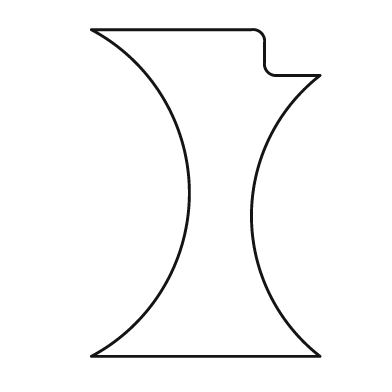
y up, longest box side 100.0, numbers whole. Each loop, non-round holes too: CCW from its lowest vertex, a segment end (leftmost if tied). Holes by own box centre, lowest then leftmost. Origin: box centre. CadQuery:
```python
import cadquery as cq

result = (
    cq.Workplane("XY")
    .moveTo(-35.0, -50.0)
    .lineTo(35.0, -50.0)
    .threePointArc((14.0, -7.0), (35.0, 36.0))
    .lineTo(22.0, 36.0)
    .threePointArc((19.0, 37.0), (18.0, 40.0))
    .lineTo(18.0, 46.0)
    .threePointArc((17.0, 49.0), (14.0, 50.0))
    .lineTo(-35.0, 50.0)
    .threePointArc((-5.0, 0.0), (-35.0, -50.0))
    .close()
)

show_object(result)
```